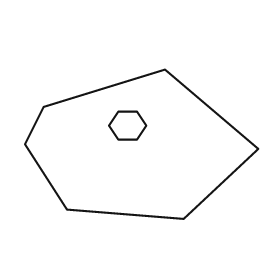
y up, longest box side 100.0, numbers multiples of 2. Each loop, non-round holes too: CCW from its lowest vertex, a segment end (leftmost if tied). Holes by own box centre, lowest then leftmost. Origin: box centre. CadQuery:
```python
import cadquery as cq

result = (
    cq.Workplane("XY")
    .moveTo(18.0, -32.0)
    .lineTo(50.0, -2.0)
    .lineTo(10.0, 32.0)
    .lineTo(-42.0, 16.0)
    .lineTo(-50.0, 0.0)
    .lineTo(-32.0, -28.0)
    .close()
    .moveTo(-10.0, 2.0)
    .lineTo(-2.0, 2.0)
    .lineTo(2.0, 8.0)
    .lineTo(-2.0, 14.0)
    .lineTo(-10.0, 14.0)
    .lineTo(-14.0, 8.0)
    .close()
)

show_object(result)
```